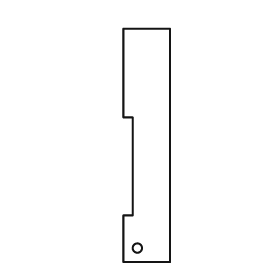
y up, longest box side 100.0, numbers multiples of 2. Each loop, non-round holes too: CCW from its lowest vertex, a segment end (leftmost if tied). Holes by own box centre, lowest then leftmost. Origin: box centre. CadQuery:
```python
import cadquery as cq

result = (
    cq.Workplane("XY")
    .moveTo(-10.0, -50.0)
    .lineTo(10.0, -50.0)
    .lineTo(10.0, 50.0)
    .lineTo(-10.0, 50.0)
    .lineTo(-10.0, 12.0)
    .lineTo(-6.0, 12.0)
    .lineTo(-6.0, -30.0)
    .lineTo(-10.0, -30.0)
    .close()
    .moveTo(-4.0, -44.0)
    .circle(2.0)
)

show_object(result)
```